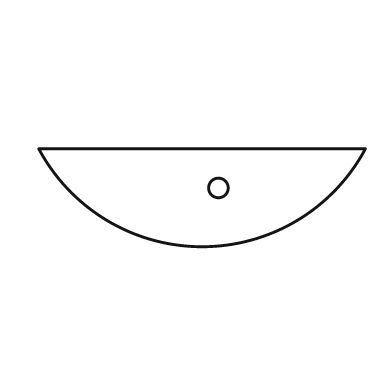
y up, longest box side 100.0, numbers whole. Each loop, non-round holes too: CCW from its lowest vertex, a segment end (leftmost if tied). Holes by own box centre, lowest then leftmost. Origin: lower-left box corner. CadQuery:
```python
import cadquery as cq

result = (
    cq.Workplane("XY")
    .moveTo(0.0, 30.0)
    .threePointArc((50.0, 0.0), (100.0, 30.0))
    .close()
    .moveTo(55.0, 18.0)
    .circle(3.0)
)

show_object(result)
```